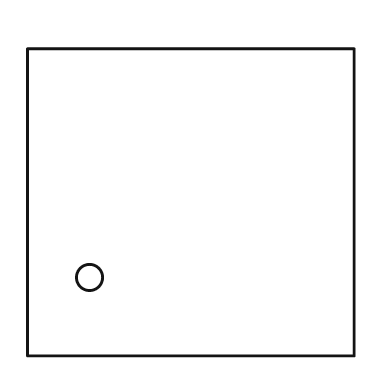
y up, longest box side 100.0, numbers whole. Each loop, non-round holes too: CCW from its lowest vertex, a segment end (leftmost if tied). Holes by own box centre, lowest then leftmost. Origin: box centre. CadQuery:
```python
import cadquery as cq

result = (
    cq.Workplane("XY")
    .moveTo(-50.0, -47.0)
    .lineTo(50.0, -47.0)
    .lineTo(50.0, 47.0)
    .lineTo(-50.0, 47.0)
    .close()
    .moveTo(-31.0, -23.0)
    .circle(4.0)
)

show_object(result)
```